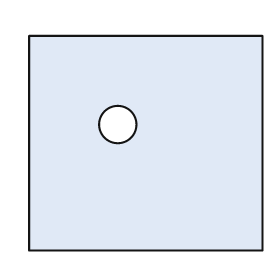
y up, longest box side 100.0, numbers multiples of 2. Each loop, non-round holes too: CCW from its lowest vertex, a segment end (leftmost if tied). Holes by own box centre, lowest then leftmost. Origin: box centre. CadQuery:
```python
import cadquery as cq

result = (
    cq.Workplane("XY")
    .moveTo(-50.0, -46.0)
    .lineTo(50.0, -46.0)
    .lineTo(50.0, 46.0)
    .lineTo(-50.0, 46.0)
    .close()
    .moveTo(-12.0, 8.0)
    .circle(8.0)
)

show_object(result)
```